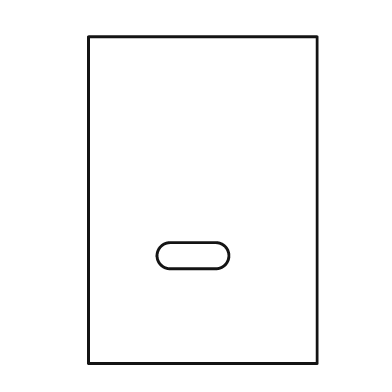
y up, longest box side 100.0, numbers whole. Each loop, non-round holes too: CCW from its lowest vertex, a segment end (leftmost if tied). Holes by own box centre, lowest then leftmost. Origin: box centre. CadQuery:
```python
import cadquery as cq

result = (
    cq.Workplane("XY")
    .moveTo(-35.0, -50.0)
    .lineTo(35.0, -50.0)
    .lineTo(35.0, 50.0)
    .lineTo(-35.0, 50.0)
    .close()
    .moveTo(-10.0, -21.0)
    .lineTo(4.0, -21.0)
    .threePointArc((8.0, -17.0), (4.0, -13.0))
    .lineTo(-10.0, -13.0)
    .threePointArc((-14.0, -17.0), (-10.0, -21.0))
    .close()
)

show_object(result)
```